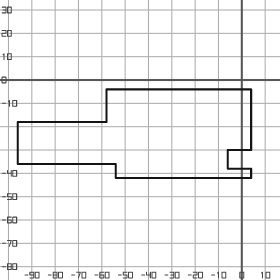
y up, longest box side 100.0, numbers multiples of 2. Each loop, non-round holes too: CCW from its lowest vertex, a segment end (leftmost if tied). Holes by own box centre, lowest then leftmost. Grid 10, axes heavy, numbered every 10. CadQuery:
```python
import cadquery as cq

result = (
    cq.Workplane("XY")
    .moveTo(-54.0, -42.0)
    .lineTo(4.0, -42.0)
    .lineTo(4.0, -38.0)
    .lineTo(-6.0, -38.0)
    .lineTo(-6.0, -30.0)
    .lineTo(4.0, -30.0)
    .lineTo(4.0, -4.0)
    .lineTo(-58.0, -4.0)
    .lineTo(-58.0, -18.0)
    .lineTo(-96.0, -18.0)
    .lineTo(-96.0, -36.0)
    .lineTo(-54.0, -36.0)
    .close()
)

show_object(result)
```